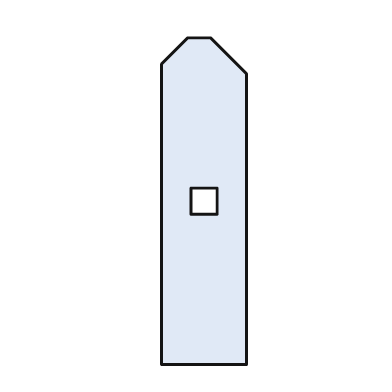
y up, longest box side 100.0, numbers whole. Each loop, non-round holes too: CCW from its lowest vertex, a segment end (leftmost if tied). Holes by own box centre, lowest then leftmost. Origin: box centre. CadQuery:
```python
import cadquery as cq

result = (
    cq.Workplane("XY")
    .moveTo(-13.0, -50.0)
    .lineTo(13.0, -50.0)
    .lineTo(13.0, 39.0)
    .lineTo(2.0, 50.0)
    .lineTo(-5.0, 50.0)
    .lineTo(-13.0, 42.0)
    .close()
    .moveTo(-4.0, -4.0)
    .lineTo(4.0, -4.0)
    .lineTo(4.0, 4.0)
    .lineTo(-4.0, 4.0)
    .close()
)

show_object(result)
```